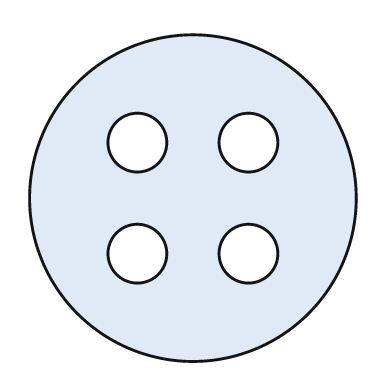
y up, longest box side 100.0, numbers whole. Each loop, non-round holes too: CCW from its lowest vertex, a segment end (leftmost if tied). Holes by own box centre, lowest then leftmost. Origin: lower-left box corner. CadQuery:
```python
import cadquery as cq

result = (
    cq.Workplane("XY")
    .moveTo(50.0, 50.0)
    .circle(50.0)
    .moveTo(33.0, 33.0)
    .circle(9.0)
    .moveTo(67.0, 33.0)
    .circle(9.0)
    .moveTo(33.0, 67.0)
    .circle(9.0)
    .moveTo(67.0, 67.0)
    .circle(9.0)
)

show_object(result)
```